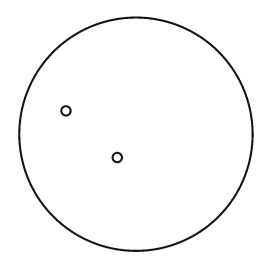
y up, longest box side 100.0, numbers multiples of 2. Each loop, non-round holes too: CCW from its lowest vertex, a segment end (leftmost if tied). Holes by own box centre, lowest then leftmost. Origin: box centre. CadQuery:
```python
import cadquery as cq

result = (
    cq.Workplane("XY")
    .moveTo(0.0, 0.0)
    .circle(50.0)
    .moveTo(-8.0, -10.0)
    .circle(2.0)
    .moveTo(-30.0, 10.0)
    .circle(2.0)
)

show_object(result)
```